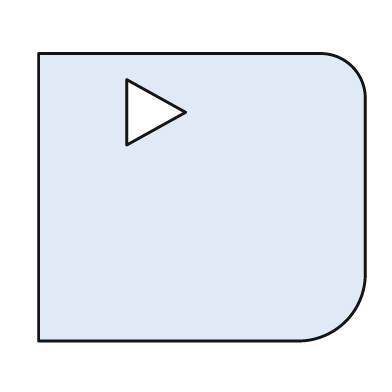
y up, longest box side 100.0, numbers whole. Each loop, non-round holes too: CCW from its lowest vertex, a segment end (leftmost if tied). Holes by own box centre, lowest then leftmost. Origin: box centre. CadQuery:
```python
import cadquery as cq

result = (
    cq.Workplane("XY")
    .moveTo(-50.0, -44.0)
    .lineTo(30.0, -44.0)
    .threePointArc((44.0, -38.0), (50.0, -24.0))
    .lineTo(50.0, 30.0)
    .threePointArc((46.0, 40.0), (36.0, 44.0))
    .lineTo(-50.0, 44.0)
    .close()
    .moveTo(-23.0, 16.0)
    .lineTo(-5.0, 26.0)
    .lineTo(-23.0, 36.0)
    .close()
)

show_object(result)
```